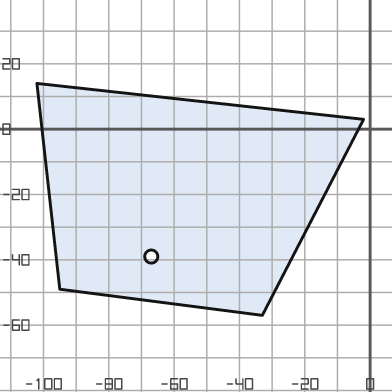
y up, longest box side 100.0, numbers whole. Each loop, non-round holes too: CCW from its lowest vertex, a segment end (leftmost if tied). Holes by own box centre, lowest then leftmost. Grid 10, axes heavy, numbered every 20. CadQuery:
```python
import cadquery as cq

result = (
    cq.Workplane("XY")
    .moveTo(-33.0, -57.0)
    .lineTo(-2.0, 3.0)
    .lineTo(-102.0, 14.0)
    .lineTo(-95.0, -49.0)
    .close()
    .moveTo(-67.0, -39.0)
    .circle(2.0)
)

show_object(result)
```